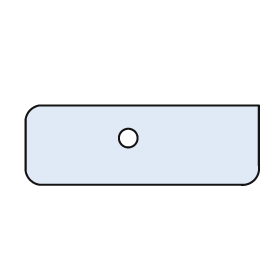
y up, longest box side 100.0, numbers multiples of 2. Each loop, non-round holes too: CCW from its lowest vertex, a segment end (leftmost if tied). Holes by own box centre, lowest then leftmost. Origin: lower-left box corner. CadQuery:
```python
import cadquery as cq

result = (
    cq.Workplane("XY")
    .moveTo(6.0, 0.0)
    .lineTo(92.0, 0.0)
    .threePointArc((98.0, 2.0), (100.0, 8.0))
    .lineTo(100.0, 34.0)
    .lineTo(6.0, 34.0)
    .threePointArc((2.0, 32.0), (0.0, 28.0))
    .lineTo(0.0, 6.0)
    .threePointArc((2.0, 2.0), (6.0, 0.0))
    .close()
    .moveTo(44.0, 20.0)
    .circle(4.0)
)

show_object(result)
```